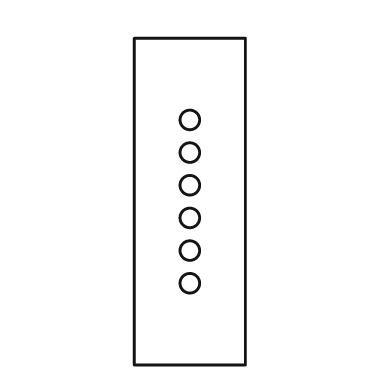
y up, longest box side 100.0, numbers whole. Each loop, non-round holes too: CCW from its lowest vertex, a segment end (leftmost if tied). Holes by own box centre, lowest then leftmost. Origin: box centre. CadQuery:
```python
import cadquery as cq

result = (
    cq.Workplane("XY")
    .moveTo(-17.0, -50.0)
    .lineTo(17.0, -50.0)
    .lineTo(17.0, 50.0)
    .lineTo(-17.0, 50.0)
    .close()
    .moveTo(0.0, -25.0)
    .circle(3.0)
    .moveTo(0.0, -15.0)
    .circle(3.0)
    .moveTo(0.0, -5.0)
    .circle(3.0)
    .moveTo(0.0, 5.0)
    .circle(3.0)
    .moveTo(0.0, 15.0)
    .circle(3.0)
    .moveTo(0.0, 25.0)
    .circle(3.0)
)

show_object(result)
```